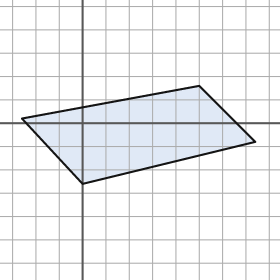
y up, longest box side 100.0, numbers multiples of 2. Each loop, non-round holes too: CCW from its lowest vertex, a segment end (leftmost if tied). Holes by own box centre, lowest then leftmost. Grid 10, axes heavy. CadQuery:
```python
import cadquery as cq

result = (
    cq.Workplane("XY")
    .moveTo(0.0, -26.0)
    .lineTo(74.0, -8.0)
    .lineTo(50.0, 16.0)
    .lineTo(-26.0, 2.0)
    .close()
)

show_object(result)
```